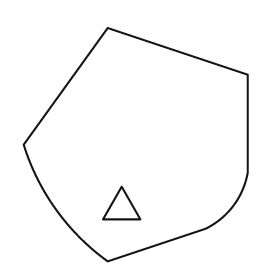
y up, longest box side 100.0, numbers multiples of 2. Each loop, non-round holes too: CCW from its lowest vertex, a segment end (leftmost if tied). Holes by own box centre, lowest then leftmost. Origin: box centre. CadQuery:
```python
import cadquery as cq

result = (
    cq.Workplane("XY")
    .moveTo(-12.0, -50.0)
    .lineTo(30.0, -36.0)
    .threePointArc((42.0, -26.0), (48.0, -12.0))
    .lineTo(48.0, 30.0)
    .lineTo(-12.0, 50.0)
    .lineTo(-48.0, 0.0)
    .threePointArc((-34.0, -28.0), (-12.0, -50.0))
    .close()
    .moveTo(-14.0, -32.0)
    .lineTo(2.0, -32.0)
    .lineTo(-6.0, -18.0)
    .close()
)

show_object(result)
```